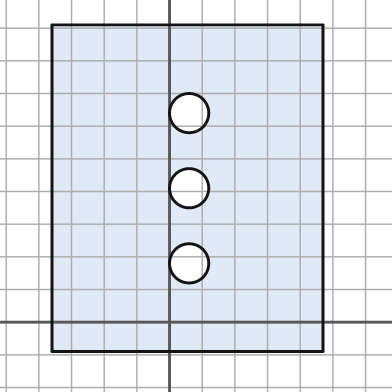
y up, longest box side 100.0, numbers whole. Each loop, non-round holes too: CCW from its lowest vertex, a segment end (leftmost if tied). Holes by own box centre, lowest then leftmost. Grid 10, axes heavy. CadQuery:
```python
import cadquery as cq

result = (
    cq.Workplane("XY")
    .moveTo(-36.0, -9.0)
    .lineTo(47.0, -9.0)
    .lineTo(47.0, 91.0)
    .lineTo(-36.0, 91.0)
    .close()
    .moveTo(6.0, 18.0)
    .circle(6.0)
    .moveTo(6.0, 41.0)
    .circle(6.0)
    .moveTo(6.0, 64.0)
    .circle(6.0)
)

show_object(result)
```